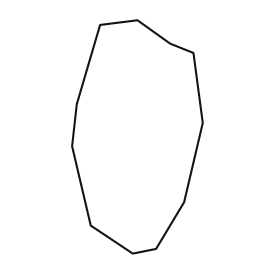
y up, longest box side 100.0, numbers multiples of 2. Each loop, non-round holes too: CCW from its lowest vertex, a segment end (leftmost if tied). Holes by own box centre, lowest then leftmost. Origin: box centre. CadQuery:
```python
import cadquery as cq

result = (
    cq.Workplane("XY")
    .moveTo(-2.0, -50.0)
    .lineTo(8.0, -48.0)
    .lineTo(20.0, -28.0)
    .lineTo(28.0, 6.0)
    .lineTo(24.0, 36.0)
    .lineTo(14.0, 40.0)
    .lineTo(0.0, 50.0)
    .lineTo(-16.0, 48.0)
    .lineTo(-26.0, 14.0)
    .lineTo(-28.0, -4.0)
    .lineTo(-20.0, -38.0)
    .close()
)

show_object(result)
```